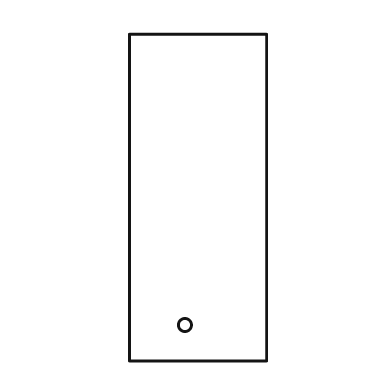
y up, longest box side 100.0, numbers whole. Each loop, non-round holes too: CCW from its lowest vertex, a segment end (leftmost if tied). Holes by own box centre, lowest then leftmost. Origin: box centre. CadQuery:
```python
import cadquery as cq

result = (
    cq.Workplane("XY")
    .moveTo(-21.0, -50.0)
    .lineTo(21.0, -50.0)
    .lineTo(21.0, 50.0)
    .lineTo(-21.0, 50.0)
    .close()
    .moveTo(-4.0, -39.0)
    .circle(2.0)
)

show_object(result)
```